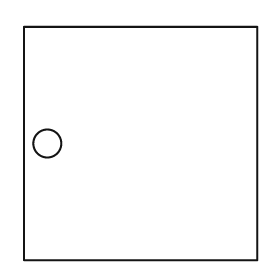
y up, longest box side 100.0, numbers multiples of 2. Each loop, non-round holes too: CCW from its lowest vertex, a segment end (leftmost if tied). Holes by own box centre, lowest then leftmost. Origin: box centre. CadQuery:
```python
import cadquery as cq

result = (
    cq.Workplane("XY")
    .moveTo(-50.0, -50.0)
    .lineTo(50.0, -50.0)
    .lineTo(50.0, 50.0)
    .lineTo(-50.0, 50.0)
    .close()
    .moveTo(-40.0, 0.0)
    .circle(6.0)
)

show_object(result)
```